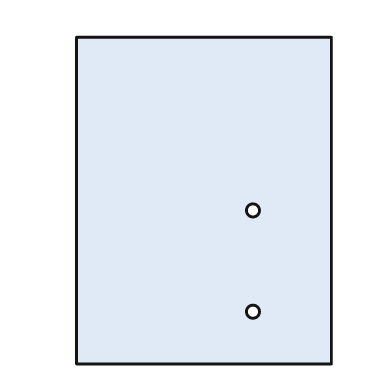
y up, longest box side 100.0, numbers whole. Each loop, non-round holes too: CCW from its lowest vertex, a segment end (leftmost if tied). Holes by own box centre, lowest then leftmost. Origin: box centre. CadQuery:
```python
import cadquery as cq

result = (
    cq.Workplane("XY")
    .moveTo(-39.0, -50.0)
    .lineTo(39.0, -50.0)
    .lineTo(39.0, 50.0)
    .lineTo(-39.0, 50.0)
    .close()
    .moveTo(15.0, -34.0)
    .circle(2.0)
    .moveTo(15.0, -3.0)
    .circle(2.0)
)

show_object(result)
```